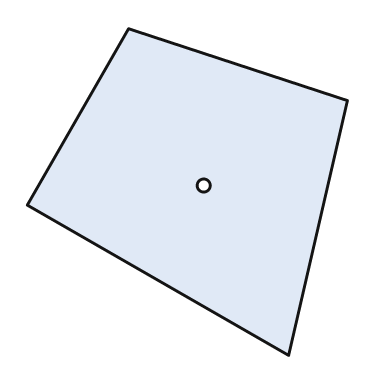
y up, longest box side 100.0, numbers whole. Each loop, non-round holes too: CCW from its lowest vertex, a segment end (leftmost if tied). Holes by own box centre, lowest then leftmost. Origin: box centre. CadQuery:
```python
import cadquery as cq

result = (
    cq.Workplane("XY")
    .moveTo(31.0, -50.0)
    .lineTo(49.0, 28.0)
    .lineTo(-18.0, 50.0)
    .lineTo(-49.0, -4.0)
    .close()
    .moveTo(5.0, 2.0)
    .circle(2.0)
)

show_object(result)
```